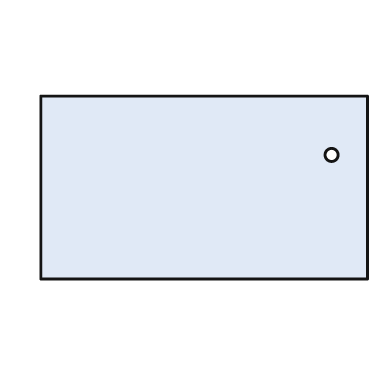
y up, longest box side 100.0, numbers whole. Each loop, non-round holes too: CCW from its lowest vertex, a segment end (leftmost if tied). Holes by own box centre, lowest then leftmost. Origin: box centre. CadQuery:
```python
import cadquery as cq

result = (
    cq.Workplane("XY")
    .moveTo(-50.0, -28.0)
    .lineTo(50.0, -28.0)
    .lineTo(50.0, 28.0)
    .lineTo(-50.0, 28.0)
    .close()
    .moveTo(39.0, 10.0)
    .circle(2.0)
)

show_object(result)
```